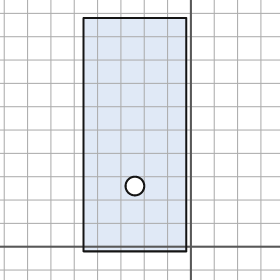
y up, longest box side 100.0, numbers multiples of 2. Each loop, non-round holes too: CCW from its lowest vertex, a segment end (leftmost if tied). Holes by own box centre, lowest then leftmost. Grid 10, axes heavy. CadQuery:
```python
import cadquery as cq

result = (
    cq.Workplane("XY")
    .moveTo(-46.0, -2.0)
    .lineTo(-2.0, -2.0)
    .lineTo(-2.0, 98.0)
    .lineTo(-46.0, 98.0)
    .close()
    .moveTo(-24.0, 26.0)
    .circle(4.0)
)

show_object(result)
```